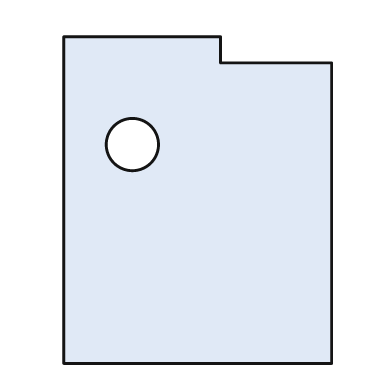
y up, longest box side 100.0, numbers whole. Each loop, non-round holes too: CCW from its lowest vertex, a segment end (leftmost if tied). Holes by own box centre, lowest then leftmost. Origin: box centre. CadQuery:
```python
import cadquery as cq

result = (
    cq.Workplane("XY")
    .moveTo(-41.0, -50.0)
    .lineTo(41.0, -50.0)
    .lineTo(41.0, 42.0)
    .lineTo(7.0, 42.0)
    .lineTo(7.0, 50.0)
    .lineTo(-41.0, 50.0)
    .close()
    .moveTo(-20.0, 17.0)
    .circle(8.0)
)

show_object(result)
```